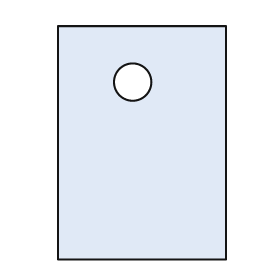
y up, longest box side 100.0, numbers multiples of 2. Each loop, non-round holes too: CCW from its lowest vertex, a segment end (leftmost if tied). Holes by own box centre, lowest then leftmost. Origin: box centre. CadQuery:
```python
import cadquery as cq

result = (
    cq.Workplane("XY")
    .moveTo(-36.0, -50.0)
    .lineTo(36.0, -50.0)
    .lineTo(36.0, 50.0)
    .lineTo(-36.0, 50.0)
    .close()
    .moveTo(-4.0, 26.0)
    .circle(8.0)
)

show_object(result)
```